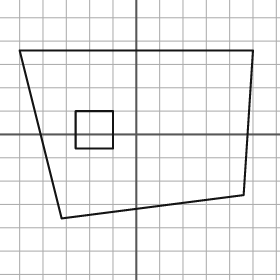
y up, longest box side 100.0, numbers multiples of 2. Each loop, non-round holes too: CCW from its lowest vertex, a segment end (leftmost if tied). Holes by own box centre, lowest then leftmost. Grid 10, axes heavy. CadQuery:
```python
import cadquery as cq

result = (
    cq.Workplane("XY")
    .moveTo(-32.0, -36.0)
    .lineTo(46.0, -26.0)
    .lineTo(50.0, 36.0)
    .lineTo(-50.0, 36.0)
    .close()
    .moveTo(-26.0, -6.0)
    .lineTo(-10.0, -6.0)
    .lineTo(-10.0, 10.0)
    .lineTo(-26.0, 10.0)
    .close()
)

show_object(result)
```